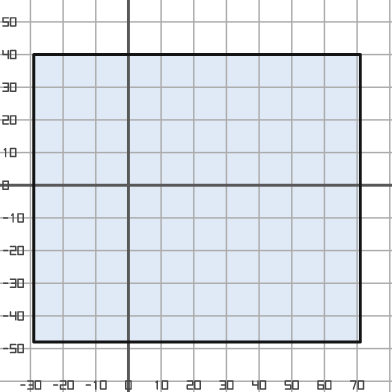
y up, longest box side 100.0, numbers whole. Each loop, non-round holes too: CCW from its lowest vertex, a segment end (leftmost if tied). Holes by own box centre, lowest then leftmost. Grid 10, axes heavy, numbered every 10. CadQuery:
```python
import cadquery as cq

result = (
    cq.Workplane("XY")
    .moveTo(-29.0, -48.0)
    .lineTo(71.0, -48.0)
    .lineTo(71.0, 40.0)
    .lineTo(-29.0, 40.0)
    .close()
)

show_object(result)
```